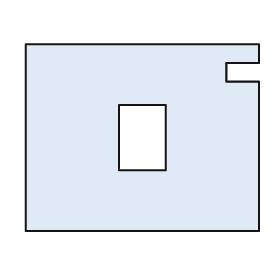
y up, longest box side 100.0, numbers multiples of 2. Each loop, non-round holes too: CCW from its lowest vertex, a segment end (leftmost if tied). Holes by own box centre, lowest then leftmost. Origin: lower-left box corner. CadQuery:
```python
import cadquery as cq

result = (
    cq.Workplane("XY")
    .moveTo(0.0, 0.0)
    .lineTo(100.0, 0.0)
    .lineTo(100.0, 64.0)
    .lineTo(86.0, 64.0)
    .lineTo(86.0, 72.0)
    .lineTo(100.0, 72.0)
    .lineTo(100.0, 80.0)
    .lineTo(0.0, 80.0)
    .close()
    .moveTo(40.0, 26.0)
    .lineTo(60.0, 26.0)
    .lineTo(60.0, 54.0)
    .lineTo(40.0, 54.0)
    .close()
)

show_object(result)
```